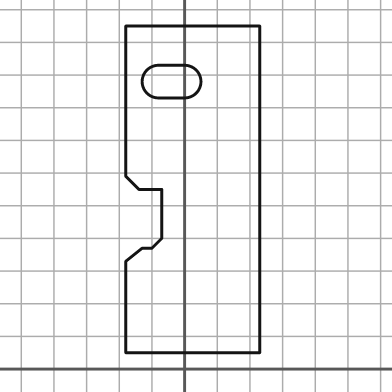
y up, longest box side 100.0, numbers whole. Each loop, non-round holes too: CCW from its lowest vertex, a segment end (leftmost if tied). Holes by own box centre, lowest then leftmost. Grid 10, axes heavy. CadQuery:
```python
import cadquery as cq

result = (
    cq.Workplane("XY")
    .moveTo(-18.0, 5.0)
    .lineTo(23.0, 5.0)
    .lineTo(23.0, 105.0)
    .lineTo(-18.0, 105.0)
    .lineTo(-18.0, 59.0)
    .lineTo(-14.0, 55.0)
    .lineTo(-7.0, 55.0)
    .lineTo(-7.0, 40.0)
    .lineTo(-10.0, 37.0)
    .lineTo(-13.0, 37.0)
    .lineTo(-18.0, 33.0)
    .close()
    .moveTo(-8.0, 83.0)
    .lineTo(0.0, 83.0)
    .threePointArc((5.0, 88.0), (0.0, 93.0))
    .lineTo(-8.0, 93.0)
    .threePointArc((-13.0, 88.0), (-8.0, 83.0))
    .close()
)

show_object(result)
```